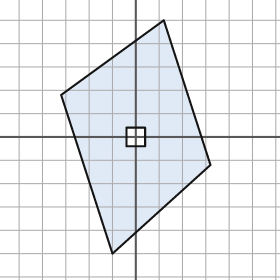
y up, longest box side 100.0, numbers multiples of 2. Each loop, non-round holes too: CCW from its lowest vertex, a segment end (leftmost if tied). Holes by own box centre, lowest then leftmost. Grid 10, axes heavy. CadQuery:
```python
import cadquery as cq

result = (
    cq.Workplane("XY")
    .moveTo(-10.0, -50.0)
    .lineTo(32.0, -12.0)
    .lineTo(12.0, 50.0)
    .lineTo(-32.0, 18.0)
    .close()
    .moveTo(-4.0, -4.0)
    .lineTo(4.0, -4.0)
    .lineTo(4.0, 4.0)
    .lineTo(-4.0, 4.0)
    .close()
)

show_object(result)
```